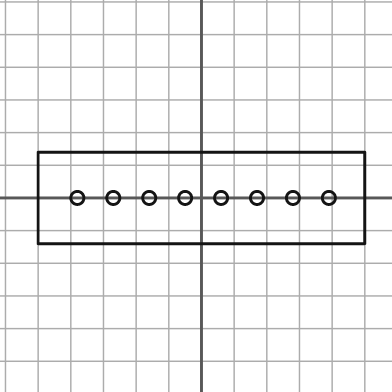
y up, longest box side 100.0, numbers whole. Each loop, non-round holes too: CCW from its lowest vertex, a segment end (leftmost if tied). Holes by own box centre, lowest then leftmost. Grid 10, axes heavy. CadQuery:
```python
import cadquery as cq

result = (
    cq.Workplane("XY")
    .moveTo(-50.0, -14.0)
    .lineTo(50.0, -14.0)
    .lineTo(50.0, 14.0)
    .lineTo(-50.0, 14.0)
    .close()
    .moveTo(-38.0, 0.0)
    .circle(2.0)
    .moveTo(-27.0, 0.0)
    .circle(2.0)
    .moveTo(-16.0, 0.0)
    .circle(2.0)
    .moveTo(-5.0, 0.0)
    .circle(2.0)
    .moveTo(6.0, 0.0)
    .circle(2.0)
    .moveTo(17.0, 0.0)
    .circle(2.0)
    .moveTo(28.0, 0.0)
    .circle(2.0)
    .moveTo(39.0, 0.0)
    .circle(2.0)
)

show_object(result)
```